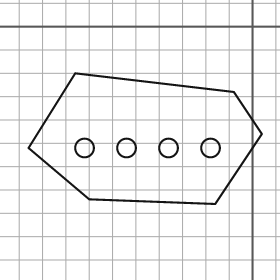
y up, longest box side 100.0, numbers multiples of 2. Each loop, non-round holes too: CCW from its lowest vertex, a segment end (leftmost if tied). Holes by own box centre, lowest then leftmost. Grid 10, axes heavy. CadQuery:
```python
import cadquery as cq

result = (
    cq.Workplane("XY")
    .moveTo(-16.0, -76.0)
    .lineTo(4.0, -46.0)
    .lineTo(-8.0, -28.0)
    .lineTo(-76.0, -20.0)
    .lineTo(-96.0, -52.0)
    .lineTo(-70.0, -74.0)
    .close()
    .moveTo(-72.0, -52.0)
    .circle(4.0)
    .moveTo(-54.0, -52.0)
    .circle(4.0)
    .moveTo(-36.0, -52.0)
    .circle(4.0)
    .moveTo(-18.0, -52.0)
    .circle(4.0)
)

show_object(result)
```